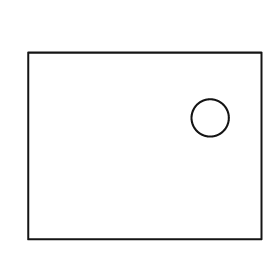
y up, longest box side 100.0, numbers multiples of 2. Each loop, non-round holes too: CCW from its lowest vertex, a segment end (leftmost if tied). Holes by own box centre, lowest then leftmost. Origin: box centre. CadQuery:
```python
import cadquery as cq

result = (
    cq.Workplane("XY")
    .moveTo(-50.0, -40.0)
    .lineTo(50.0, -40.0)
    .lineTo(50.0, 40.0)
    .lineTo(-50.0, 40.0)
    .close()
    .moveTo(28.0, 12.0)
    .circle(8.0)
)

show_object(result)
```